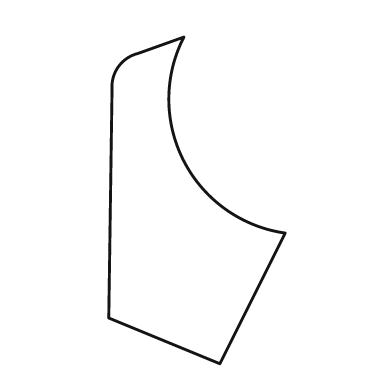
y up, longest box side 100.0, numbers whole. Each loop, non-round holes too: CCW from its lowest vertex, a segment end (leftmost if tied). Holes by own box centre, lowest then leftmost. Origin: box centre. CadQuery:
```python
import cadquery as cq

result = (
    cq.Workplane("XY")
    .moveTo(7.0, -50.0)
    .lineTo(27.0, -10.0)
    .threePointArc((-4.0, 12.0), (-4.0, 50.0))
    .lineTo(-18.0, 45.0)
    .threePointArc((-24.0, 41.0), (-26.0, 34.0))
    .lineTo(-27.0, -36.0)
    .close()
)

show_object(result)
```